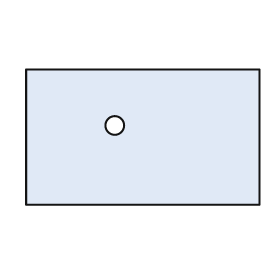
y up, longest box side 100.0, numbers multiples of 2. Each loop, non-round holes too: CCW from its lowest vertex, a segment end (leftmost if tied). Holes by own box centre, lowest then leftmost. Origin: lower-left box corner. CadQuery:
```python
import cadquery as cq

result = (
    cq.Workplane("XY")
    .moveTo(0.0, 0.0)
    .lineTo(100.0, 0.0)
    .lineTo(100.0, 58.0)
    .lineTo(0.0, 58.0)
    .close()
    .moveTo(38.0, 34.0)
    .circle(4.0)
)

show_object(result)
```